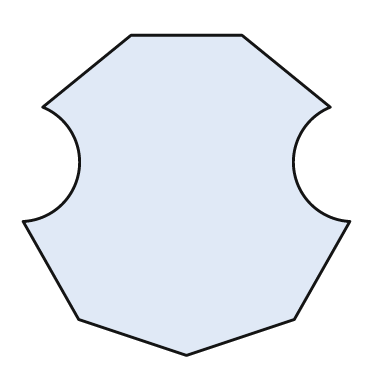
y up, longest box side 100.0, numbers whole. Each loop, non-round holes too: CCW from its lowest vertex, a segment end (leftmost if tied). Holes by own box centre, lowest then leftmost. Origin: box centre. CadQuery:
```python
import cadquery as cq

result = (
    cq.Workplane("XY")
    .moveTo(0.0, -49.0)
    .lineTo(33.0, -38.0)
    .lineTo(50.0, -8.0)
    .threePointArc((33.0, 7.0), (44.0, 27.0))
    .lineTo(17.0, 49.0)
    .lineTo(-17.0, 49.0)
    .lineTo(-44.0, 27.0)
    .threePointArc((-33.0, 7.0), (-50.0, -8.0))
    .lineTo(-33.0, -38.0)
    .close()
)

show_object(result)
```